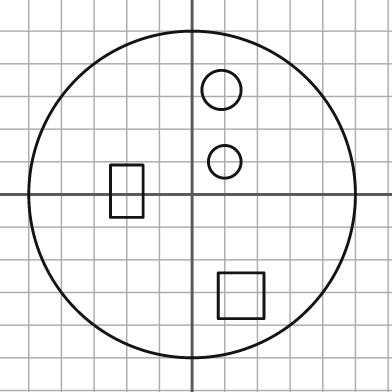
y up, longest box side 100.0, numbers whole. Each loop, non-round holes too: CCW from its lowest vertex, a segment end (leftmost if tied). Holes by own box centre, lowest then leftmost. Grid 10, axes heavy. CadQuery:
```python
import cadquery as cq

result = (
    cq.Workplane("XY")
    .moveTo(0.0, 0.0)
    .circle(50.0)
    .moveTo(8.0, -38.0)
    .lineTo(22.0, -38.0)
    .lineTo(22.0, -24.0)
    .lineTo(8.0, -24.0)
    .close()
    .moveTo(-25.0, -7.0)
    .lineTo(-15.0, -7.0)
    .lineTo(-15.0, 9.0)
    .lineTo(-25.0, 9.0)
    .close()
    .moveTo(10.0, 10.0)
    .circle(5.0)
    .moveTo(9.0, 32.0)
    .circle(6.0)
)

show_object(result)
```